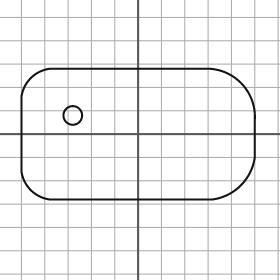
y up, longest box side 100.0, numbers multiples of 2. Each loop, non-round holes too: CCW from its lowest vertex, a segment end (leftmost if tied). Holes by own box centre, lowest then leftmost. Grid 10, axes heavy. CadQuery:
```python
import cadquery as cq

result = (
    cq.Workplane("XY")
    .moveTo(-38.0, -28.0)
    .lineTo(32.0, -28.0)
    .threePointArc((44.0, -22.0), (50.0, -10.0))
    .lineTo(50.0, 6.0)
    .threePointArc((44.0, 22.0), (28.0, 28.0))
    .lineTo(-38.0, 28.0)
    .threePointArc((-46.0, 24.0), (-50.0, 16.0))
    .lineTo(-50.0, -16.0)
    .threePointArc((-46.0, -24.0), (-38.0, -28.0))
    .close()
    .moveTo(-28.0, 8.0)
    .circle(4.0)
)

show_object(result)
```